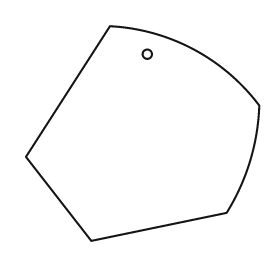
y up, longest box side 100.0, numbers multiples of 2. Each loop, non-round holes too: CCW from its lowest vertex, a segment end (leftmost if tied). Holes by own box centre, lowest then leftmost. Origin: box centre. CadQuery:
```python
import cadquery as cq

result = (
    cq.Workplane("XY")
    .moveTo(-22.0, -46.0)
    .lineTo(36.0, -34.0)
    .threePointArc((46.0, -12.0), (50.0, 12.0))
    .threePointArc((22.0, 36.0), (-14.0, 46.0))
    .lineTo(-50.0, -10.0)
    .close()
    .moveTo(2.0, 34.0)
    .circle(2.0)
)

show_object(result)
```